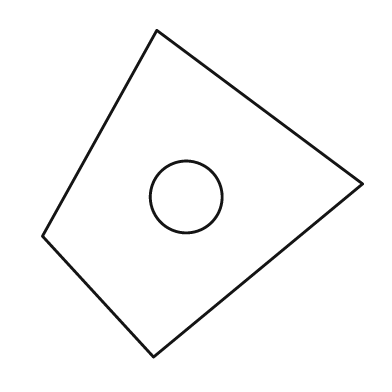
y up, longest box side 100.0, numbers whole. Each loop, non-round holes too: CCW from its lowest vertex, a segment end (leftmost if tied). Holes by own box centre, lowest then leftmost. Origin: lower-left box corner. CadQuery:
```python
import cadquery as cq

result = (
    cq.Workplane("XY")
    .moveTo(34.0, 0.0)
    .lineTo(98.0, 53.0)
    .lineTo(35.0, 100.0)
    .lineTo(0.0, 37.0)
    .close()
    .moveTo(44.0, 49.0)
    .circle(11.0)
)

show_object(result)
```